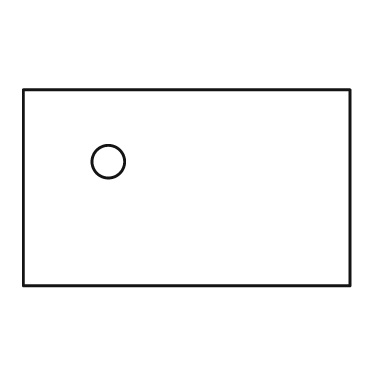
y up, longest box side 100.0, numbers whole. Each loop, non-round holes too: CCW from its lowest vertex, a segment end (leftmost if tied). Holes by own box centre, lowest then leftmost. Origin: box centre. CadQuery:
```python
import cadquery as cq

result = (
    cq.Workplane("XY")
    .moveTo(-50.0, -30.0)
    .lineTo(50.0, -30.0)
    .lineTo(50.0, 30.0)
    .lineTo(-50.0, 30.0)
    .close()
    .moveTo(-24.0, 8.0)
    .circle(5.0)
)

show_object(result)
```